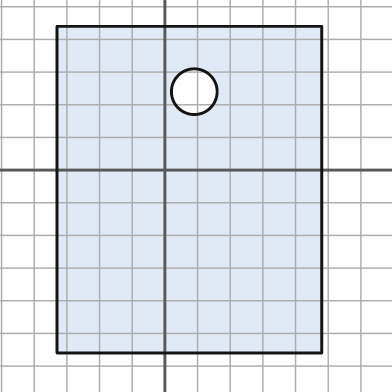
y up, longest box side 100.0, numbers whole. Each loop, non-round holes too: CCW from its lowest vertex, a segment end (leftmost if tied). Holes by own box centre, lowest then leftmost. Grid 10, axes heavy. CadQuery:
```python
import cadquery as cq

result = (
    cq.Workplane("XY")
    .moveTo(-33.0, -56.0)
    .lineTo(48.0, -56.0)
    .lineTo(48.0, 44.0)
    .lineTo(-33.0, 44.0)
    .close()
    .moveTo(9.0, 24.0)
    .circle(7.0)
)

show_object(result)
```